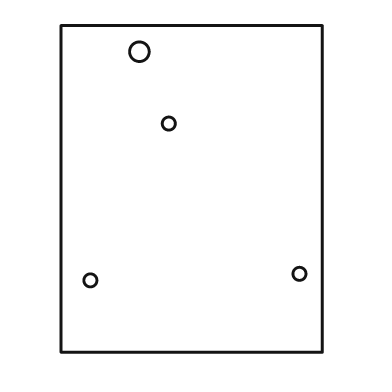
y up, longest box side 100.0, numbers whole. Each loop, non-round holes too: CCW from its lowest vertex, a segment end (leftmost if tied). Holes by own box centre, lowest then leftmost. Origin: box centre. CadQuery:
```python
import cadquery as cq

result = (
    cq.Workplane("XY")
    .moveTo(-40.0, -50.0)
    .lineTo(40.0, -50.0)
    .lineTo(40.0, 50.0)
    .lineTo(-40.0, 50.0)
    .close()
    .moveTo(-31.0, -28.0)
    .circle(2.0)
    .moveTo(33.0, -26.0)
    .circle(2.0)
    .moveTo(-7.0, 20.0)
    .circle(2.0)
    .moveTo(-16.0, 42.0)
    .circle(3.0)
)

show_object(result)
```